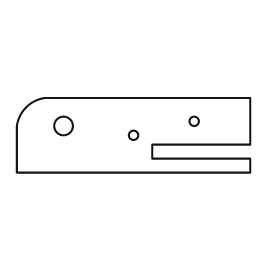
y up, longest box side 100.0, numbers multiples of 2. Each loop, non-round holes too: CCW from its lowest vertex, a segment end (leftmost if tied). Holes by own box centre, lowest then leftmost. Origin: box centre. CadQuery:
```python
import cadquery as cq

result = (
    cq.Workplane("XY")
    .moveTo(-50.0, -16.0)
    .lineTo(50.0, -16.0)
    .lineTo(50.0, -10.0)
    .lineTo(8.0, -10.0)
    .lineTo(8.0, -4.0)
    .lineTo(50.0, -4.0)
    .lineTo(50.0, 16.0)
    .lineTo(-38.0, 16.0)
    .threePointArc((-46.0, 12.0), (-50.0, 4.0))
    .close()
    .moveTo(0.0, 0.0)
    .circle(2.0)
    .moveTo(-30.0, 4.0)
    .circle(4.0)
    .moveTo(26.0, 6.0)
    .circle(2.0)
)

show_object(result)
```